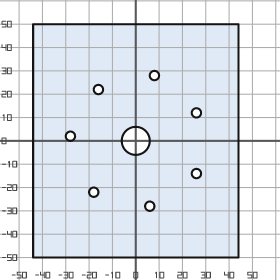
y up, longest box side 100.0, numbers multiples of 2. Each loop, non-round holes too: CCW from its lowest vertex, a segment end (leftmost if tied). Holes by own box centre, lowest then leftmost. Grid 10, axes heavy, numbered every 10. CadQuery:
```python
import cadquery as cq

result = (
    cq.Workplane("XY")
    .moveTo(-44.0, -50.0)
    .lineTo(44.0, -50.0)
    .lineTo(44.0, 50.0)
    .lineTo(-44.0, 50.0)
    .close()
    .moveTo(6.0, -28.0)
    .circle(2.0)
    .moveTo(-18.0, -22.0)
    .circle(2.0)
    .moveTo(26.0, -14.0)
    .circle(2.0)
    .moveTo(0.0, 0.0)
    .circle(6.0)
    .moveTo(-28.0, 2.0)
    .circle(2.0)
    .moveTo(26.0, 12.0)
    .circle(2.0)
    .moveTo(-16.0, 22.0)
    .circle(2.0)
    .moveTo(8.0, 28.0)
    .circle(2.0)
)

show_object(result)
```